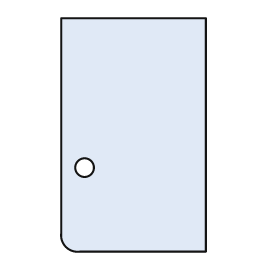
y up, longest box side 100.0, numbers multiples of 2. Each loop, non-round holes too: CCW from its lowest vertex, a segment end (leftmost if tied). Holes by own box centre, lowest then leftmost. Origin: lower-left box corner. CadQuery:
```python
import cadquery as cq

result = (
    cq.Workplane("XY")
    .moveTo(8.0, 0.0)
    .lineTo(62.0, 0.0)
    .lineTo(62.0, 100.0)
    .lineTo(0.0, 100.0)
    .lineTo(0.0, 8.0)
    .threePointArc((2.0, 2.0), (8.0, 0.0))
    .close()
    .moveTo(10.0, 36.0)
    .circle(4.0)
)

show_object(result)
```